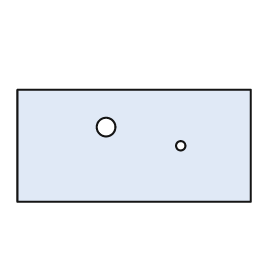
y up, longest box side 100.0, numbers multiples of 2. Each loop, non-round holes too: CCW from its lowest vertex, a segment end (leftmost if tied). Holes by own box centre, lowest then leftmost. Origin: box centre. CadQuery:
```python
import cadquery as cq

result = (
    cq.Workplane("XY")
    .moveTo(-50.0, -24.0)
    .lineTo(50.0, -24.0)
    .lineTo(50.0, 24.0)
    .lineTo(-50.0, 24.0)
    .close()
    .moveTo(20.0, 0.0)
    .circle(2.0)
    .moveTo(-12.0, 8.0)
    .circle(4.0)
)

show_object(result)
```